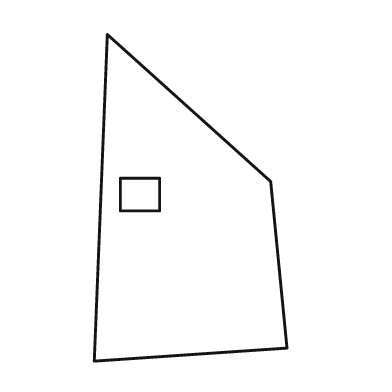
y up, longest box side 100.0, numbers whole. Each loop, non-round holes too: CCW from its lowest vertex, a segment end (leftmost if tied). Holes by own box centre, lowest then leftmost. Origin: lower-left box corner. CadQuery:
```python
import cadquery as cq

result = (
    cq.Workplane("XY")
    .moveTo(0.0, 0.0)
    .lineTo(59.0, 4.0)
    .lineTo(54.0, 55.0)
    .lineTo(4.0, 100.0)
    .close()
    .moveTo(8.0, 46.0)
    .lineTo(20.0, 46.0)
    .lineTo(20.0, 56.0)
    .lineTo(8.0, 56.0)
    .close()
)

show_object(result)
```